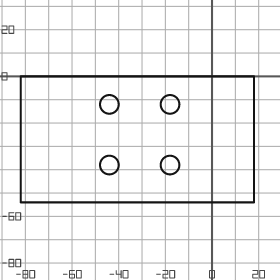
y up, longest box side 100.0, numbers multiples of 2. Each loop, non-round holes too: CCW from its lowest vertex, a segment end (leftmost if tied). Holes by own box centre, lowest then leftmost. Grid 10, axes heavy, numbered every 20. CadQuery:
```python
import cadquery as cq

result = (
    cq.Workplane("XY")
    .moveTo(-82.0, -54.0)
    .lineTo(18.0, -54.0)
    .lineTo(18.0, 0.0)
    .lineTo(-82.0, 0.0)
    .close()
    .moveTo(-44.0, -38.0)
    .circle(4.0)
    .moveTo(-18.0, -38.0)
    .circle(4.0)
    .moveTo(-44.0, -12.0)
    .circle(4.0)
    .moveTo(-18.0, -12.0)
    .circle(4.0)
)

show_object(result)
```